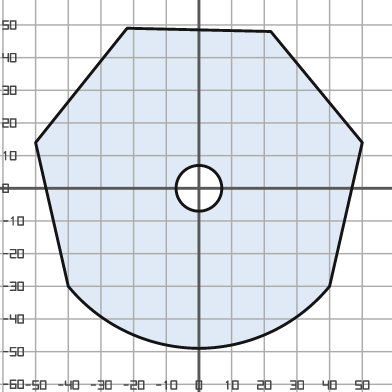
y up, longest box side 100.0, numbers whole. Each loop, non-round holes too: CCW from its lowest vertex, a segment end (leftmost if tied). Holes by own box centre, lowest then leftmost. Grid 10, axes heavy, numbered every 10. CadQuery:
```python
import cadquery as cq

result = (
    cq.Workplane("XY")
    .moveTo(0.0, -49.0)
    .threePointArc((22.0, -44.0), (40.0, -30.0))
    .lineTo(50.0, 14.0)
    .lineTo(22.0, 48.0)
    .lineTo(-22.0, 49.0)
    .lineTo(-50.0, 14.0)
    .lineTo(-40.0, -30.0)
    .threePointArc((-22.0, -44.0), (0.0, -49.0))
    .close()
    .moveTo(0.0, 0.0)
    .circle(7.0)
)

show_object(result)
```